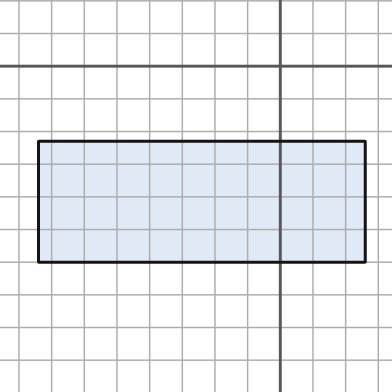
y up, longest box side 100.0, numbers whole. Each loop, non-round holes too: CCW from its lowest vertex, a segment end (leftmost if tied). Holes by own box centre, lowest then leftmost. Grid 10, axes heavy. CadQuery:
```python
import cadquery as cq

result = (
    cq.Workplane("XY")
    .moveTo(-74.0, -60.0)
    .lineTo(26.0, -60.0)
    .lineTo(26.0, -23.0)
    .lineTo(-74.0, -23.0)
    .close()
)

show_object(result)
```